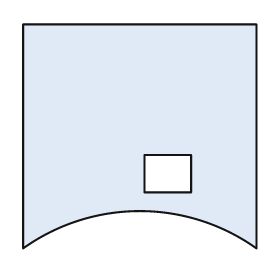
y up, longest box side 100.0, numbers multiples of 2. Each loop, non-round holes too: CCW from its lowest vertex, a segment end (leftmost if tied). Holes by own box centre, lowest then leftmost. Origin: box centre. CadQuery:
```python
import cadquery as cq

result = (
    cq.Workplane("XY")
    .moveTo(-50.0, -48.0)
    .threePointArc((0.0, -32.0), (50.0, -48.0))
    .lineTo(50.0, 48.0)
    .lineTo(-50.0, 48.0)
    .close()
    .moveTo(2.0, -24.0)
    .lineTo(22.0, -24.0)
    .lineTo(22.0, -8.0)
    .lineTo(2.0, -8.0)
    .close()
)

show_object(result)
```